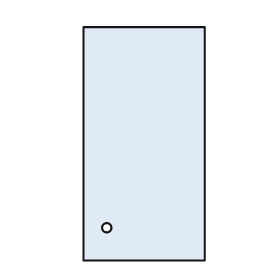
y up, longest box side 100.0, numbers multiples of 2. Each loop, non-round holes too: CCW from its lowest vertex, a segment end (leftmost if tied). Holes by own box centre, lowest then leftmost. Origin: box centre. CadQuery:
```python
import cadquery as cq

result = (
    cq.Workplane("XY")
    .moveTo(-26.0, -50.0)
    .lineTo(26.0, -50.0)
    .lineTo(26.0, 50.0)
    .lineTo(-26.0, 50.0)
    .close()
    .moveTo(-16.0, -36.0)
    .circle(2.0)
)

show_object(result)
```